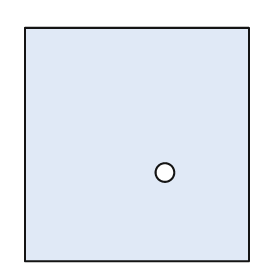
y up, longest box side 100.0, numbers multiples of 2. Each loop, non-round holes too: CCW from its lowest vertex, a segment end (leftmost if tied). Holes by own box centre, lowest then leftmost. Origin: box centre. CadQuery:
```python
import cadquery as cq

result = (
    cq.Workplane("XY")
    .moveTo(-48.0, -50.0)
    .lineTo(48.0, -50.0)
    .lineTo(48.0, 50.0)
    .lineTo(-48.0, 50.0)
    .close()
    .moveTo(12.0, -12.0)
    .circle(4.0)
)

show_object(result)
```